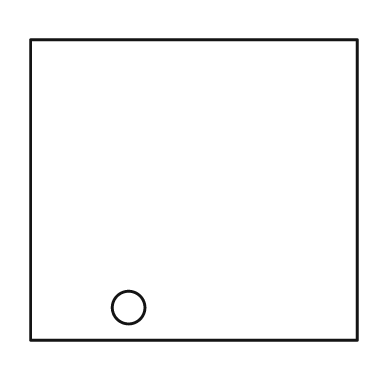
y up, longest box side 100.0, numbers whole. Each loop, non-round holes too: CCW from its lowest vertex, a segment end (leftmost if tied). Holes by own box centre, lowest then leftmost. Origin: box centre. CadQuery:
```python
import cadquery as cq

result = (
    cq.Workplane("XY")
    .moveTo(-50.0, -46.0)
    .lineTo(50.0, -46.0)
    .lineTo(50.0, 46.0)
    .lineTo(-50.0, 46.0)
    .close()
    .moveTo(-20.0, -36.0)
    .circle(5.0)
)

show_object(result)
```